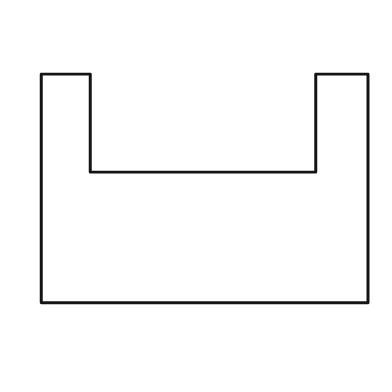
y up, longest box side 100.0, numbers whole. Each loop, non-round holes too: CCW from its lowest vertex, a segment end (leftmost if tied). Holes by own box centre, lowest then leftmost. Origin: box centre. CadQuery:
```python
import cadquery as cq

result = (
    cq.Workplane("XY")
    .moveTo(-50.0, -35.0)
    .lineTo(50.0, -35.0)
    .lineTo(50.0, 35.0)
    .lineTo(34.0, 35.0)
    .lineTo(34.0, 5.0)
    .lineTo(-35.0, 5.0)
    .lineTo(-35.0, 35.0)
    .lineTo(-50.0, 35.0)
    .close()
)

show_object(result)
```